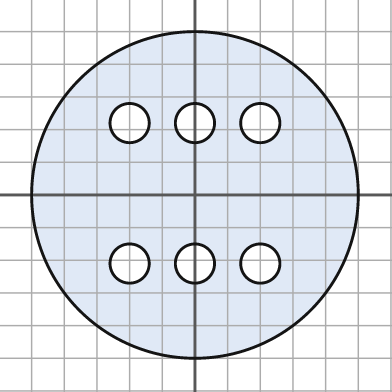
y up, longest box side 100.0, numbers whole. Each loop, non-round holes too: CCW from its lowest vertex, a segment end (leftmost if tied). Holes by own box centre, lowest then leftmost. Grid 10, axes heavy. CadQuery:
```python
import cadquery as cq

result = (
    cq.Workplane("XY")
    .moveTo(0.0, 0.0)
    .circle(50.0)
    .moveTo(-20.0, -21.0)
    .circle(6.0)
    .moveTo(0.0, -21.0)
    .circle(6.0)
    .moveTo(20.0, -21.0)
    .circle(6.0)
    .moveTo(-20.0, 22.0)
    .circle(6.0)
    .moveTo(0.0, 22.0)
    .circle(6.0)
    .moveTo(20.0, 22.0)
    .circle(6.0)
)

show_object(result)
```